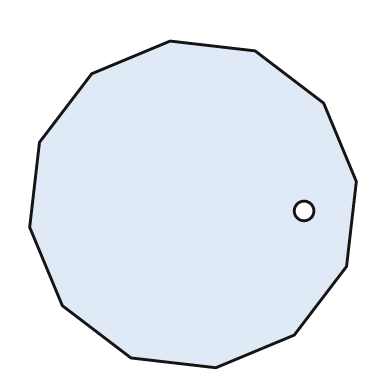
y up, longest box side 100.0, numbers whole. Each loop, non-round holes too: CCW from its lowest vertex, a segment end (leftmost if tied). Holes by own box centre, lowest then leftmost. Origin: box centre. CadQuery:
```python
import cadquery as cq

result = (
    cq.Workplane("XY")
    .moveTo(7.0, -50.0)
    .lineTo(31.0, -40.0)
    .lineTo(47.0, -19.0)
    .lineTo(50.0, 7.0)
    .lineTo(40.0, 31.0)
    .lineTo(19.0, 47.0)
    .lineTo(-7.0, 50.0)
    .lineTo(-31.0, 40.0)
    .lineTo(-47.0, 19.0)
    .lineTo(-50.0, -7.0)
    .lineTo(-40.0, -31.0)
    .lineTo(-19.0, -47.0)
    .close()
    .moveTo(34.0, -2.0)
    .circle(3.0)
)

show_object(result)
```